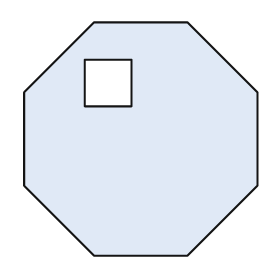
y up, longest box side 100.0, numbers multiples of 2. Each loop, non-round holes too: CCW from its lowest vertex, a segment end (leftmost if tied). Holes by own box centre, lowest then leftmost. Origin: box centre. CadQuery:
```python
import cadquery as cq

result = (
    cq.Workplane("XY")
    .moveTo(-20.0, -50.0)
    .lineTo(20.0, -50.0)
    .lineTo(50.0, -20.0)
    .lineTo(50.0, 20.0)
    .lineTo(20.0, 50.0)
    .lineTo(-20.0, 50.0)
    .lineTo(-50.0, 20.0)
    .lineTo(-50.0, -20.0)
    .close()
    .moveTo(-24.0, 14.0)
    .lineTo(-4.0, 14.0)
    .lineTo(-4.0, 34.0)
    .lineTo(-24.0, 34.0)
    .close()
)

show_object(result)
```